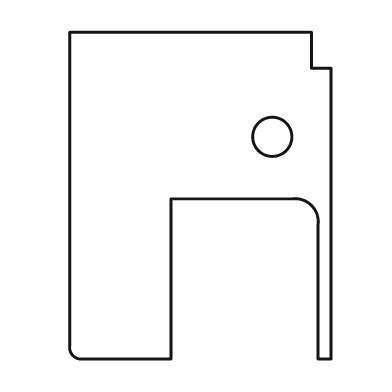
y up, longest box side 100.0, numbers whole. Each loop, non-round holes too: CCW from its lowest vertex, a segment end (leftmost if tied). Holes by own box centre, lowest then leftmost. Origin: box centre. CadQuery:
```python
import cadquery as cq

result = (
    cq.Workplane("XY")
    .moveTo(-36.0, -50.0)
    .lineTo(-9.0, -50.0)
    .lineTo(-9.0, -1.0)
    .lineTo(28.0, -1.0)
    .threePointArc((34.0, -3.0), (36.0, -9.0))
    .lineTo(36.0, -50.0)
    .lineTo(40.0, -50.0)
    .lineTo(40.0, 39.0)
    .lineTo(34.0, 39.0)
    .lineTo(34.0, 50.0)
    .lineTo(-40.0, 50.0)
    .lineTo(-40.0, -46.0)
    .threePointArc((-39.0, -49.0), (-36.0, -50.0))
    .close()
    .moveTo(22.0, 18.0)
    .circle(6.0)
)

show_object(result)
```